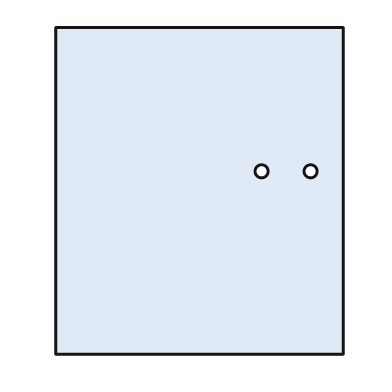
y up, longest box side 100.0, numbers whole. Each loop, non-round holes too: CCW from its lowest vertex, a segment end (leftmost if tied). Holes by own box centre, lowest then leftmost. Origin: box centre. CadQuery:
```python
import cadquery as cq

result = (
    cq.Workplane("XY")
    .moveTo(-44.0, -50.0)
    .lineTo(44.0, -50.0)
    .lineTo(44.0, 50.0)
    .lineTo(-44.0, 50.0)
    .close()
    .moveTo(19.0, 6.0)
    .circle(2.0)
    .moveTo(34.0, 6.0)
    .circle(2.0)
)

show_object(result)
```